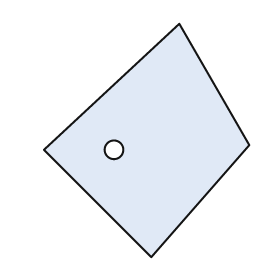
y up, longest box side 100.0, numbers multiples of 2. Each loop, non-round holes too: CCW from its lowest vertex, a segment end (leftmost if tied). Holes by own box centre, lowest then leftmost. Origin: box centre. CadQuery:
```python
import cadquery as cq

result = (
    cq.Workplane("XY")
    .moveTo(2.0, -50.0)
    .lineTo(44.0, -2.0)
    .lineTo(14.0, 50.0)
    .lineTo(-44.0, -4.0)
    .close()
    .moveTo(-14.0, -4.0)
    .circle(4.0)
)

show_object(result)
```